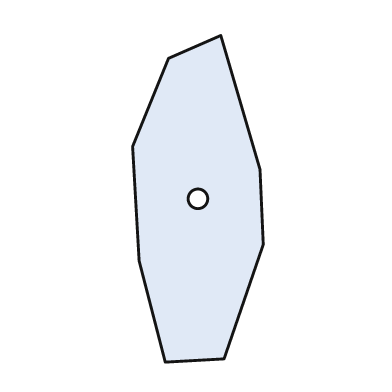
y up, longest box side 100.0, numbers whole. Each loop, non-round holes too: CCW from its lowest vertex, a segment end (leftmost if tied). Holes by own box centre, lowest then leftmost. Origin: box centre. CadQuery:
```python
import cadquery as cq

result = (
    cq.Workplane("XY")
    .moveTo(-10.0, -50.0)
    .lineTo(8.0, -49.0)
    .lineTo(20.0, -14.0)
    .lineTo(19.0, 9.0)
    .lineTo(7.0, 50.0)
    .lineTo(-9.0, 43.0)
    .lineTo(-20.0, 16.0)
    .lineTo(-18.0, -19.0)
    .close()
    .moveTo(0.0, 0.0)
    .circle(3.0)
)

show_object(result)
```